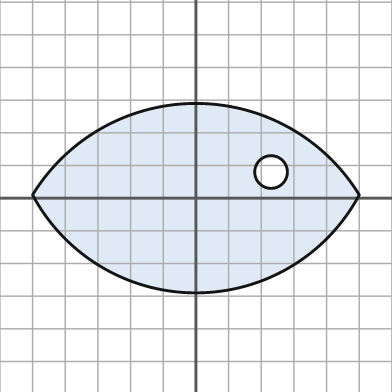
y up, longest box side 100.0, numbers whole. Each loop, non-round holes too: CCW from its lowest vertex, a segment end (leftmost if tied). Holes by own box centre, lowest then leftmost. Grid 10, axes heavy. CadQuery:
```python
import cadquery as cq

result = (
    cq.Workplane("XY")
    .moveTo(-50.0, 1.0)
    .threePointArc((0.0, -29.0), (50.0, 1.0))
    .threePointArc((0.0, 29.0), (-50.0, 1.0))
    .close()
    .moveTo(23.0, 8.0)
    .circle(5.0)
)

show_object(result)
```